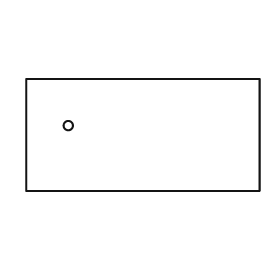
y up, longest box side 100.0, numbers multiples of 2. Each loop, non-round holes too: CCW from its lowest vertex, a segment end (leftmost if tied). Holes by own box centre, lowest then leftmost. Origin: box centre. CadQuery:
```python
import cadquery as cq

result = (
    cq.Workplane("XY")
    .moveTo(-50.0, -24.0)
    .lineTo(50.0, -24.0)
    .lineTo(50.0, 24.0)
    .lineTo(-50.0, 24.0)
    .close()
    .moveTo(-32.0, 4.0)
    .circle(2.0)
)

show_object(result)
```